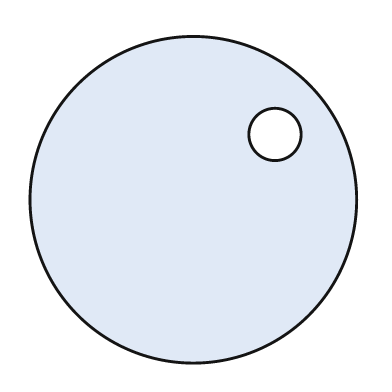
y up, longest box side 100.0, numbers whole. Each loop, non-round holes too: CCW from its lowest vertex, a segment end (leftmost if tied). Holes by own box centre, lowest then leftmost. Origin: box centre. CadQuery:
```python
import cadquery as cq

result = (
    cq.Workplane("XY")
    .moveTo(0.0, 0.0)
    .circle(50.0)
    .moveTo(25.0, 20.0)
    .circle(8.0)
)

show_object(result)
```